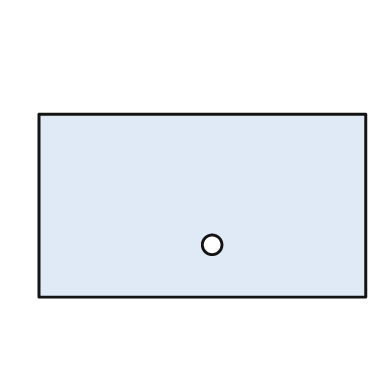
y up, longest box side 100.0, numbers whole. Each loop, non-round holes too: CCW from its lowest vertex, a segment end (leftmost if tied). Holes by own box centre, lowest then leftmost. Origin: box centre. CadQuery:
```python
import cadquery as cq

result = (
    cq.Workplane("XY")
    .moveTo(-50.0, -28.0)
    .lineTo(50.0, -28.0)
    .lineTo(50.0, 28.0)
    .lineTo(-50.0, 28.0)
    .close()
    .moveTo(3.0, -12.0)
    .circle(3.0)
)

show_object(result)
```